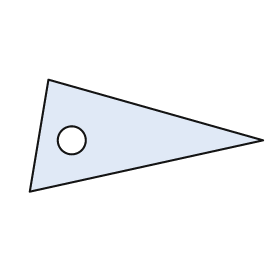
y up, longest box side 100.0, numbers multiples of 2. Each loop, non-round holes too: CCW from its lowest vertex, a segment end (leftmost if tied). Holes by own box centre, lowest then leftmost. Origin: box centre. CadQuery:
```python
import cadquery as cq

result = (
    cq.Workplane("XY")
    .moveTo(-50.0, -24.0)
    .lineTo(50.0, -2.0)
    .lineTo(-42.0, 24.0)
    .close()
    .moveTo(-32.0, -2.0)
    .circle(6.0)
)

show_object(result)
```